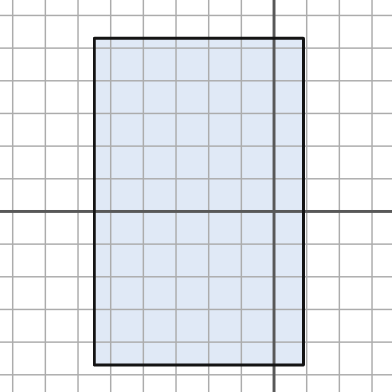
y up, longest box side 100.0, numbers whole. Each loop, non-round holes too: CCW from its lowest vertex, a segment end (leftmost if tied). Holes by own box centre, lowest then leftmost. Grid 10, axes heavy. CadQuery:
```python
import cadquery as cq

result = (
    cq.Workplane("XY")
    .moveTo(-55.0, -47.0)
    .lineTo(9.0, -47.0)
    .lineTo(9.0, 53.0)
    .lineTo(-55.0, 53.0)
    .close()
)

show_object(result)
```